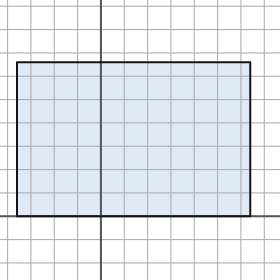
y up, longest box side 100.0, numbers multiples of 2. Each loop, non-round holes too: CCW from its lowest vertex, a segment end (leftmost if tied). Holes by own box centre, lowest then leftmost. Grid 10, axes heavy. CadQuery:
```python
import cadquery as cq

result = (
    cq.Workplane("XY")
    .moveTo(-36.0, 0.0)
    .lineTo(64.0, 0.0)
    .lineTo(64.0, 66.0)
    .lineTo(-36.0, 66.0)
    .close()
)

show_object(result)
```